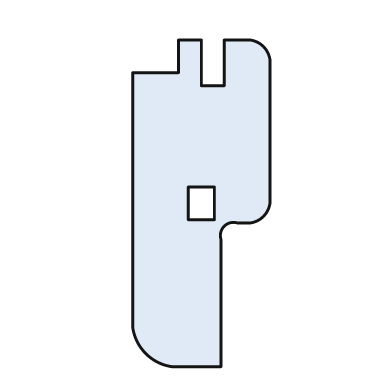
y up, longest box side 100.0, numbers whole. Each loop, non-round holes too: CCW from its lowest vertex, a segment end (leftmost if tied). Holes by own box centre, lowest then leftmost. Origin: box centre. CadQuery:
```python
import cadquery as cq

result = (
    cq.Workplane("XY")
    .moveTo(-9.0, -50.0)
    .lineTo(6.0, -50.0)
    .lineTo(6.0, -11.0)
    .threePointArc((7.0, -7.0), (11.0, -6.0))
    .lineTo(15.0, -6.0)
    .threePointArc((19.0, -4.0), (21.0, 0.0))
    .lineTo(21.0, 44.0)
    .threePointArc((19.0, 48.0), (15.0, 50.0))
    .lineTo(7.0, 50.0)
    .lineTo(7.0, 36.0)
    .lineTo(0.0, 36.0)
    .lineTo(0.0, 50.0)
    .lineTo(-7.0, 50.0)
    .lineTo(-7.0, 40.0)
    .lineTo(-21.0, 40.0)
    .lineTo(-21.0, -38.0)
    .threePointArc((-17.0, -46.0), (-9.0, -50.0))
    .close()
    .moveTo(-4.0, -5.0)
    .lineTo(4.0, -5.0)
    .lineTo(4.0, 5.0)
    .lineTo(-4.0, 5.0)
    .close()
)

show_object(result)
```